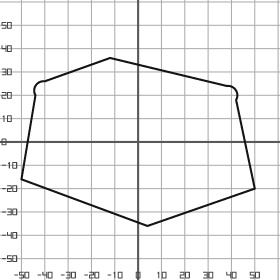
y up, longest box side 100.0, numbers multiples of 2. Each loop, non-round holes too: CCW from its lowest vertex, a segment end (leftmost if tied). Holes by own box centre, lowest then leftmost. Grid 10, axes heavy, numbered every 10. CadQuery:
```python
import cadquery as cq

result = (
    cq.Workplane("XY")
    .moveTo(4.0, -36.0)
    .lineTo(50.0, -20.0)
    .lineTo(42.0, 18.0)
    .threePointArc((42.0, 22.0), (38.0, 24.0))
    .lineTo(-12.0, 36.0)
    .lineTo(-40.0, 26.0)
    .threePointArc((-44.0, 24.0), (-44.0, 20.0))
    .lineTo(-50.0, -16.0)
    .close()
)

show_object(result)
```